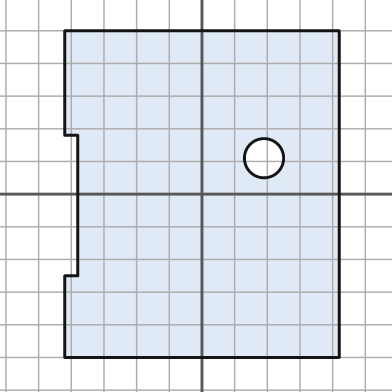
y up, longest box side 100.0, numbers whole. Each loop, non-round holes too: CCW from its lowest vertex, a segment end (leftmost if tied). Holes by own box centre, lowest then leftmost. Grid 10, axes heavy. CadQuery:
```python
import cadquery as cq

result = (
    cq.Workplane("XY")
    .moveTo(-42.0, -50.0)
    .lineTo(42.0, -50.0)
    .lineTo(42.0, 50.0)
    .lineTo(-42.0, 50.0)
    .lineTo(-42.0, 18.0)
    .lineTo(-38.0, 18.0)
    .lineTo(-38.0, -25.0)
    .lineTo(-42.0, -25.0)
    .close()
    .moveTo(19.0, 11.0)
    .circle(6.0)
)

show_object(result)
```